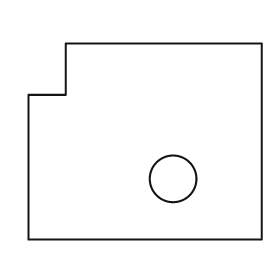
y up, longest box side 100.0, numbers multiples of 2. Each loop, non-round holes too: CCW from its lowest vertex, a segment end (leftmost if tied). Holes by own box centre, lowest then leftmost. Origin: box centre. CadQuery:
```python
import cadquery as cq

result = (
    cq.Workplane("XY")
    .moveTo(-50.0, -42.0)
    .lineTo(50.0, -42.0)
    .lineTo(50.0, 42.0)
    .lineTo(-34.0, 42.0)
    .lineTo(-34.0, 20.0)
    .lineTo(-50.0, 20.0)
    .close()
    .moveTo(12.0, -16.0)
    .circle(10.0)
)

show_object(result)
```